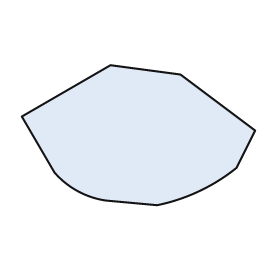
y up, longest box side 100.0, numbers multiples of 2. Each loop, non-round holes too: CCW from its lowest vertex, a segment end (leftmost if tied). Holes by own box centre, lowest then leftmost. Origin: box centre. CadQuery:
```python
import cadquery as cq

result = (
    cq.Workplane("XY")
    .moveTo(8.0, -30.0)
    .threePointArc((26.0, -24.0), (42.0, -14.0))
    .lineTo(50.0, 2.0)
    .lineTo(18.0, 26.0)
    .lineTo(-12.0, 30.0)
    .lineTo(-50.0, 8.0)
    .lineTo(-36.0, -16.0)
    .threePointArc((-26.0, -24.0), (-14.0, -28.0))
    .close()
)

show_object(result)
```